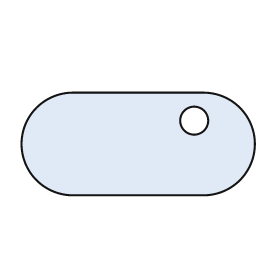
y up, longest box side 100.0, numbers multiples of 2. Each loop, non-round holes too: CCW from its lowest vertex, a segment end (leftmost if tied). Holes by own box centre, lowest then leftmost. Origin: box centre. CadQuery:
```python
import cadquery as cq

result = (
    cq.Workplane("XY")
    .moveTo(-28.0, -22.0)
    .lineTo(28.0, -22.0)
    .threePointArc((50.0, 0.0), (28.0, 22.0))
    .lineTo(-28.0, 22.0)
    .threePointArc((-50.0, 0.0), (-28.0, -22.0))
    .close()
    .moveTo(24.0, 10.0)
    .circle(6.0)
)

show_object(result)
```